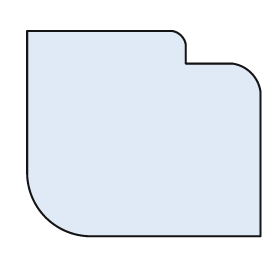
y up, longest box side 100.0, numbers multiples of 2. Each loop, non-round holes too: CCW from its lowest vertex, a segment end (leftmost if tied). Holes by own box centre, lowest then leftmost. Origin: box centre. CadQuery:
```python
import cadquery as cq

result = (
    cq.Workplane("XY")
    .moveTo(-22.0, -44.0)
    .lineTo(50.0, -44.0)
    .lineTo(50.0, 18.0)
    .threePointArc((46.0, 26.0), (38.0, 30.0))
    .lineTo(18.0, 30.0)
    .lineTo(18.0, 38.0)
    .threePointArc((16.0, 42.0), (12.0, 44.0))
    .lineTo(-50.0, 44.0)
    .lineTo(-50.0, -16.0)
    .threePointArc((-42.0, -36.0), (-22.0, -44.0))
    .close()
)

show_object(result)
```